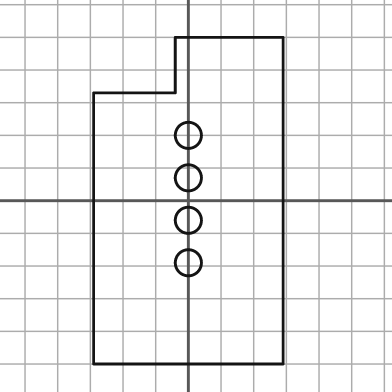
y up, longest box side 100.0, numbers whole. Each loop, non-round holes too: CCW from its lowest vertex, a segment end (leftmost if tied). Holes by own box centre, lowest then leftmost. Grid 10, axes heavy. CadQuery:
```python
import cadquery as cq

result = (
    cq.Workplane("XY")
    .moveTo(-29.0, -50.0)
    .lineTo(29.0, -50.0)
    .lineTo(29.0, 50.0)
    .lineTo(-4.0, 50.0)
    .lineTo(-4.0, 33.0)
    .lineTo(-29.0, 33.0)
    .close()
    .moveTo(0.0, -19.0)
    .circle(4.0)
    .moveTo(0.0, -6.0)
    .circle(4.0)
    .moveTo(0.0, 7.0)
    .circle(4.0)
    .moveTo(0.0, 20.0)
    .circle(4.0)
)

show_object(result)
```